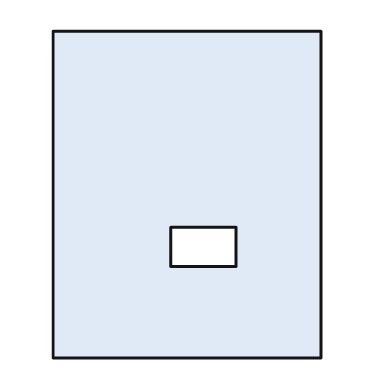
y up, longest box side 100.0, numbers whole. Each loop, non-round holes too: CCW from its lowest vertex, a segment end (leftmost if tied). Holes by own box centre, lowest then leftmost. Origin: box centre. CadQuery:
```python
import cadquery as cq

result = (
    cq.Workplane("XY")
    .moveTo(-41.0, -50.0)
    .lineTo(41.0, -50.0)
    .lineTo(41.0, 50.0)
    .lineTo(-41.0, 50.0)
    .close()
    .moveTo(-5.0, -22.0)
    .lineTo(15.0, -22.0)
    .lineTo(15.0, -10.0)
    .lineTo(-5.0, -10.0)
    .close()
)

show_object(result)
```